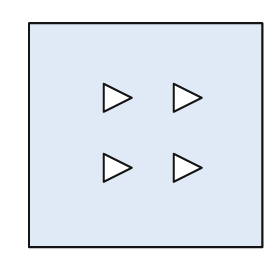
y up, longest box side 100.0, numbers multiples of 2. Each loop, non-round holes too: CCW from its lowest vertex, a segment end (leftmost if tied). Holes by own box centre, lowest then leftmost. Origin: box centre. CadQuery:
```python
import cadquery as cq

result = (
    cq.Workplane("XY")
    .moveTo(-50.0, -48.0)
    .lineTo(50.0, -48.0)
    .lineTo(50.0, 48.0)
    .lineTo(-50.0, 48.0)
    .close()
    .moveTo(-18.0, -20.0)
    .lineTo(-6.0, -14.0)
    .lineTo(-18.0, -8.0)
    .close()
    .moveTo(12.0, -20.0)
    .lineTo(24.0, -14.0)
    .lineTo(12.0, -8.0)
    .close()
    .moveTo(-18.0, 10.0)
    .lineTo(-6.0, 16.0)
    .lineTo(-18.0, 22.0)
    .close()
    .moveTo(12.0, 10.0)
    .lineTo(24.0, 16.0)
    .lineTo(12.0, 22.0)
    .close()
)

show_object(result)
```